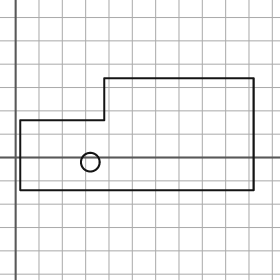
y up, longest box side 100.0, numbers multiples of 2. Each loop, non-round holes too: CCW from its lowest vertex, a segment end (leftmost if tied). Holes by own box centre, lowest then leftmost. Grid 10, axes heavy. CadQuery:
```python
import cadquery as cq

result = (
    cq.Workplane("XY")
    .moveTo(2.0, -14.0)
    .lineTo(102.0, -14.0)
    .lineTo(102.0, 34.0)
    .lineTo(38.0, 34.0)
    .lineTo(38.0, 16.0)
    .lineTo(2.0, 16.0)
    .close()
    .moveTo(32.0, -2.0)
    .circle(4.0)
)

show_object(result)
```